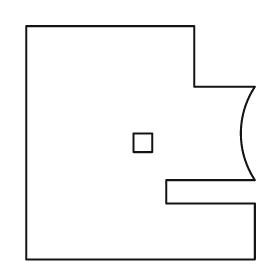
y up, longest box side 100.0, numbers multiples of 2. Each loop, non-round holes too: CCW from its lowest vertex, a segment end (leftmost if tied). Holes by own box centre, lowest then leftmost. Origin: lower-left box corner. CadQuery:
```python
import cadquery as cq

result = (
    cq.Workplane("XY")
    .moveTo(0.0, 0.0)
    .lineTo(98.0, 0.0)
    .lineTo(98.0, 24.0)
    .lineTo(60.0, 24.0)
    .lineTo(60.0, 34.0)
    .lineTo(98.0, 34.0)
    .threePointArc((92.0, 54.0), (98.0, 74.0))
    .lineTo(72.0, 74.0)
    .lineTo(72.0, 100.0)
    .lineTo(0.0, 100.0)
    .close()
    .moveTo(46.0, 46.0)
    .lineTo(54.0, 46.0)
    .lineTo(54.0, 54.0)
    .lineTo(46.0, 54.0)
    .close()
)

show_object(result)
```